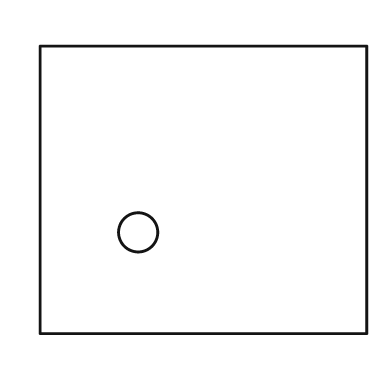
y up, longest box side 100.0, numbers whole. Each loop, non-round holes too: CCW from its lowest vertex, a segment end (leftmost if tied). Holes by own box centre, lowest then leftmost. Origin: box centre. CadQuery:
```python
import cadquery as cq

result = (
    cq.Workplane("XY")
    .moveTo(-50.0, -44.0)
    .lineTo(50.0, -44.0)
    .lineTo(50.0, 44.0)
    .lineTo(-50.0, 44.0)
    .close()
    .moveTo(-20.0, -13.0)
    .circle(6.0)
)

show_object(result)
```